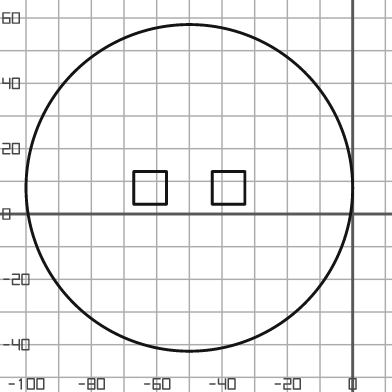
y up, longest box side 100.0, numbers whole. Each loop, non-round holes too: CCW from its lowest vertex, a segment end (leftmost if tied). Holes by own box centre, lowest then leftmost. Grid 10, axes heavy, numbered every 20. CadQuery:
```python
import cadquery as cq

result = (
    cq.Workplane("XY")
    .moveTo(-50.0, 8.0)
    .circle(50.0)
    .moveTo(-67.0, 3.0)
    .lineTo(-57.0, 3.0)
    .lineTo(-57.0, 13.0)
    .lineTo(-67.0, 13.0)
    .close()
    .moveTo(-43.0, 3.0)
    .lineTo(-33.0, 3.0)
    .lineTo(-33.0, 13.0)
    .lineTo(-43.0, 13.0)
    .close()
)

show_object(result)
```